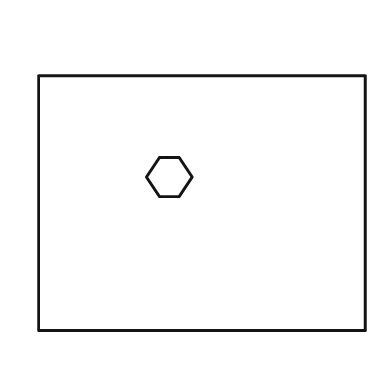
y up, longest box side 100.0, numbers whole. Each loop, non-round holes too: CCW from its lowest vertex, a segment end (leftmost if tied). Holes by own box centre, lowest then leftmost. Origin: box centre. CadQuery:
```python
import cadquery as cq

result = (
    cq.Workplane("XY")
    .moveTo(-50.0, -39.0)
    .lineTo(50.0, -39.0)
    .lineTo(50.0, 39.0)
    .lineTo(-50.0, 39.0)
    .close()
    .moveTo(-13.0, 2.0)
    .lineTo(-7.0, 2.0)
    .lineTo(-3.0, 8.0)
    .lineTo(-7.0, 14.0)
    .lineTo(-13.0, 14.0)
    .lineTo(-17.0, 8.0)
    .close()
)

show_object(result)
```